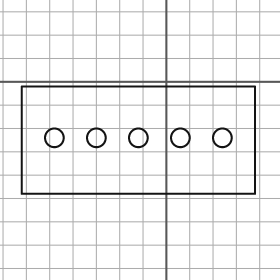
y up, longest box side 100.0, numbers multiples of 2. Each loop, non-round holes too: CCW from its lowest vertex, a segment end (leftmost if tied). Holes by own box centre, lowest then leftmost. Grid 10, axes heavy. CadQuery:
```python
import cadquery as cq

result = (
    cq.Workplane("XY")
    .moveTo(-62.0, -48.0)
    .lineTo(38.0, -48.0)
    .lineTo(38.0, -2.0)
    .lineTo(-62.0, -2.0)
    .close()
    .moveTo(-48.0, -24.0)
    .circle(4.0)
    .moveTo(-30.0, -24.0)
    .circle(4.0)
    .moveTo(-12.0, -24.0)
    .circle(4.0)
    .moveTo(6.0, -24.0)
    .circle(4.0)
    .moveTo(24.0, -24.0)
    .circle(4.0)
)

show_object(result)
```